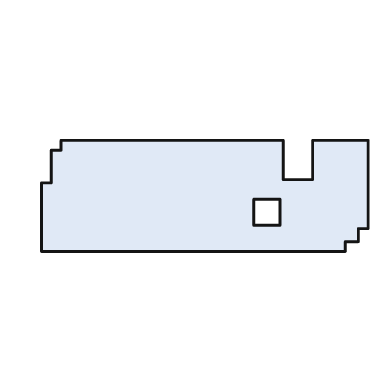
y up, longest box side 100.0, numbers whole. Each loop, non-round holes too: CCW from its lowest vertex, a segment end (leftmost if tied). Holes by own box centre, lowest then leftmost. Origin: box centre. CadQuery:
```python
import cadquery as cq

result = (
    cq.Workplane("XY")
    .moveTo(-50.0, -17.0)
    .lineTo(43.0, -17.0)
    .lineTo(43.0, -14.0)
    .lineTo(47.0, -14.0)
    .lineTo(47.0, -10.0)
    .lineTo(50.0, -10.0)
    .lineTo(50.0, 17.0)
    .lineTo(33.0, 17.0)
    .lineTo(33.0, 5.0)
    .lineTo(24.0, 5.0)
    .lineTo(24.0, 17.0)
    .lineTo(-44.0, 17.0)
    .lineTo(-44.0, 14.0)
    .lineTo(-47.0, 14.0)
    .lineTo(-47.0, 4.0)
    .lineTo(-50.0, 4.0)
    .close()
    .moveTo(15.0, -9.0)
    .lineTo(23.0, -9.0)
    .lineTo(23.0, -1.0)
    .lineTo(15.0, -1.0)
    .close()
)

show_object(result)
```